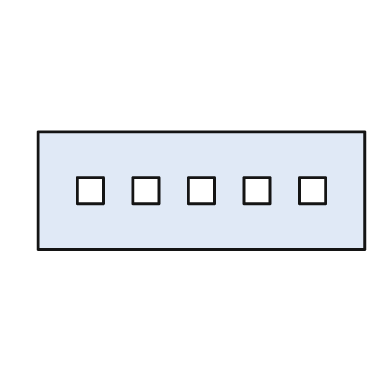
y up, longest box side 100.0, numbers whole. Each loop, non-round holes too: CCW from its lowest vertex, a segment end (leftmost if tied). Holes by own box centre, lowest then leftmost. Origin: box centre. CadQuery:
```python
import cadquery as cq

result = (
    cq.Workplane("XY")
    .moveTo(-50.0, -18.0)
    .lineTo(50.0, -18.0)
    .lineTo(50.0, 18.0)
    .lineTo(-50.0, 18.0)
    .close()
    .moveTo(-38.0, -4.0)
    .lineTo(-30.0, -4.0)
    .lineTo(-30.0, 4.0)
    .lineTo(-38.0, 4.0)
    .close()
    .moveTo(-21.0, -4.0)
    .lineTo(-13.0, -4.0)
    .lineTo(-13.0, 4.0)
    .lineTo(-21.0, 4.0)
    .close()
    .moveTo(-4.0, -4.0)
    .lineTo(4.0, -4.0)
    .lineTo(4.0, 4.0)
    .lineTo(-4.0, 4.0)
    .close()
    .moveTo(13.0, -4.0)
    .lineTo(21.0, -4.0)
    .lineTo(21.0, 4.0)
    .lineTo(13.0, 4.0)
    .close()
    .moveTo(30.0, -4.0)
    .lineTo(38.0, -4.0)
    .lineTo(38.0, 4.0)
    .lineTo(30.0, 4.0)
    .close()
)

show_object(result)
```